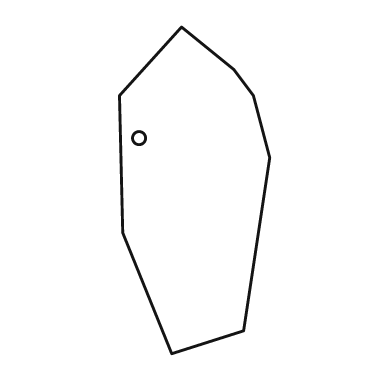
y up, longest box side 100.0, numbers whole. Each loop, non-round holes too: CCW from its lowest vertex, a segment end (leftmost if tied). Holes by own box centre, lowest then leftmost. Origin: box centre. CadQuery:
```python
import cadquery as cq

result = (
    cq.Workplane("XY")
    .moveTo(-7.0, -50.0)
    .lineTo(15.0, -43.0)
    .lineTo(23.0, 10.0)
    .lineTo(18.0, 29.0)
    .lineTo(12.0, 37.0)
    .lineTo(-4.0, 50.0)
    .lineTo(-23.0, 29.0)
    .lineTo(-22.0, -13.0)
    .close()
    .moveTo(-17.0, 16.0)
    .circle(2.0)
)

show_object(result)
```